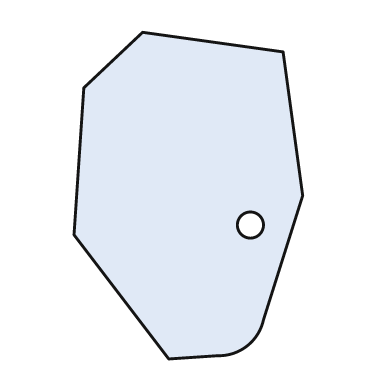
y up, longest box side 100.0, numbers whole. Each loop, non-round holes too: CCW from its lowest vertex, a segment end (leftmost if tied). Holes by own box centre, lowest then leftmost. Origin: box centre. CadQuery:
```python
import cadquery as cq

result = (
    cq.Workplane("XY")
    .moveTo(-6.0, -50.0)
    .lineTo(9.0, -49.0)
    .threePointArc((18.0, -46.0), (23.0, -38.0))
    .lineTo(35.0, 0.0)
    .lineTo(29.0, 44.0)
    .lineTo(-14.0, 50.0)
    .lineTo(-32.0, 33.0)
    .lineTo(-35.0, -12.0)
    .close()
    .moveTo(19.0, -9.0)
    .circle(4.0)
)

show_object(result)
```